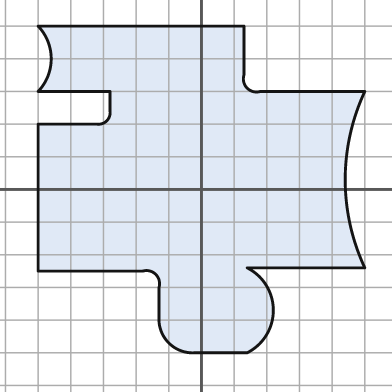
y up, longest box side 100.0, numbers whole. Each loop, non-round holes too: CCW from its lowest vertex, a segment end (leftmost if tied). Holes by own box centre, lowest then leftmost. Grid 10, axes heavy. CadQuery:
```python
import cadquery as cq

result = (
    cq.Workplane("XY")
    .moveTo(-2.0, -50.0)
    .lineTo(14.0, -50.0)
    .threePointArc((22.0, -37.0), (14.0, -24.0))
    .lineTo(50.0, -24.0)
    .threePointArc((44.0, 3.0), (50.0, 30.0))
    .lineTo(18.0, 30.0)
    .threePointArc((14.0, 31.0), (13.0, 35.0))
    .lineTo(13.0, 50.0)
    .lineTo(-50.0, 50.0)
    .threePointArc((-46.0, 40.0), (-50.0, 30.0))
    .lineTo(-28.0, 30.0)
    .lineTo(-28.0, 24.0)
    .threePointArc((-29.0, 21.0), (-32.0, 20.0))
    .lineTo(-50.0, 20.0)
    .lineTo(-50.0, -25.0)
    .lineTo(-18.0, -25.0)
    .threePointArc((-14.0, -26.0), (-13.0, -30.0))
    .lineTo(-13.0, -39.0)
    .threePointArc((-10.0, -47.0), (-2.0, -50.0))
    .close()
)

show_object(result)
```